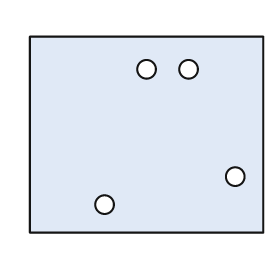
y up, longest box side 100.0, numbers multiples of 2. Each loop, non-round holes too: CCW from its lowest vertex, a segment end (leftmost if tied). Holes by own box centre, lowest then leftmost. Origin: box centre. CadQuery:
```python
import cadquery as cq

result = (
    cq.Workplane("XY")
    .moveTo(-50.0, -42.0)
    .lineTo(50.0, -42.0)
    .lineTo(50.0, 42.0)
    .lineTo(-50.0, 42.0)
    .close()
    .moveTo(-18.0, -30.0)
    .circle(4.0)
    .moveTo(38.0, -18.0)
    .circle(4.0)
    .moveTo(0.0, 28.0)
    .circle(4.0)
    .moveTo(18.0, 28.0)
    .circle(4.0)
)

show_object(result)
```